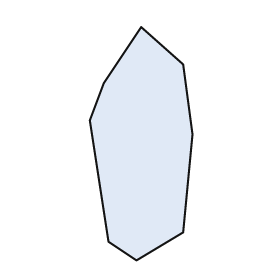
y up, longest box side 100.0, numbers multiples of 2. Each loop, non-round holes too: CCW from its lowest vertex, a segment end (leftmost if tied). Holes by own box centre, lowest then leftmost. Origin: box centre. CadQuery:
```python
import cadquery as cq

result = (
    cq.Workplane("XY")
    .moveTo(-2.0, -50.0)
    .lineTo(18.0, -38.0)
    .lineTo(22.0, 4.0)
    .lineTo(18.0, 34.0)
    .lineTo(0.0, 50.0)
    .lineTo(-16.0, 26.0)
    .lineTo(-22.0, 10.0)
    .lineTo(-14.0, -42.0)
    .close()
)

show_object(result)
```